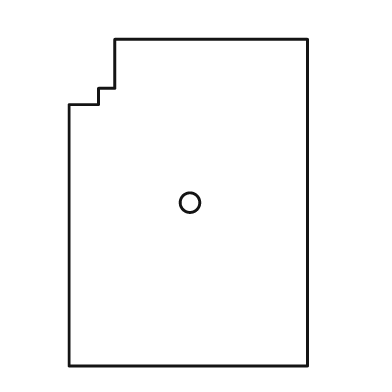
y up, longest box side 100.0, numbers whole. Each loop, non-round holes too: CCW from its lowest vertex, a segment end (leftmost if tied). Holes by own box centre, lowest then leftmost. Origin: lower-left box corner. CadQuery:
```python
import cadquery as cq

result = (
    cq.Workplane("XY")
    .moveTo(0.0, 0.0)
    .lineTo(73.0, 0.0)
    .lineTo(73.0, 100.0)
    .lineTo(14.0, 100.0)
    .lineTo(14.0, 85.0)
    .lineTo(9.0, 85.0)
    .lineTo(9.0, 80.0)
    .lineTo(0.0, 80.0)
    .close()
    .moveTo(37.0, 50.0)
    .circle(3.0)
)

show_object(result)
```